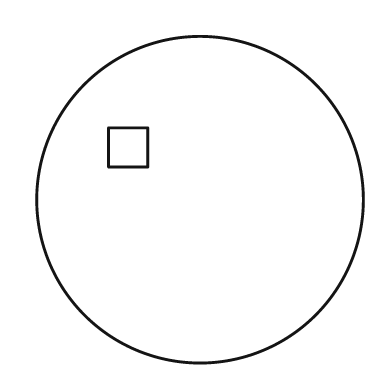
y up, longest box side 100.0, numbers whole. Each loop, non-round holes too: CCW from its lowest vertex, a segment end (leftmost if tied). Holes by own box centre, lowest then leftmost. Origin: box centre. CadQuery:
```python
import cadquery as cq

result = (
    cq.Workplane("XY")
    .moveTo(0.0, 0.0)
    .circle(50.0)
    .moveTo(-28.0, 10.0)
    .lineTo(-16.0, 10.0)
    .lineTo(-16.0, 22.0)
    .lineTo(-28.0, 22.0)
    .close()
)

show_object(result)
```